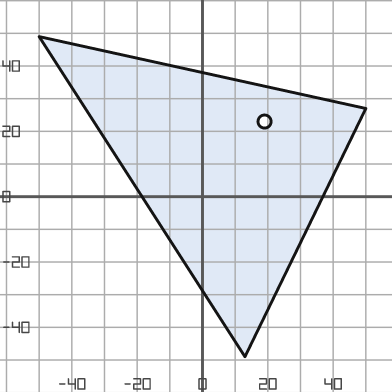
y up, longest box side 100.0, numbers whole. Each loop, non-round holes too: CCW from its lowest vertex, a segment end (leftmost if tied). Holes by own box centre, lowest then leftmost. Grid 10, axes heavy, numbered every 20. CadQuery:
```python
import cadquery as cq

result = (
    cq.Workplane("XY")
    .moveTo(13.0, -49.0)
    .lineTo(50.0, 27.0)
    .lineTo(-50.0, 49.0)
    .close()
    .moveTo(19.0, 23.0)
    .circle(2.0)
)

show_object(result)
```